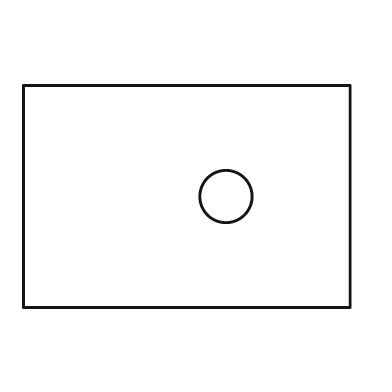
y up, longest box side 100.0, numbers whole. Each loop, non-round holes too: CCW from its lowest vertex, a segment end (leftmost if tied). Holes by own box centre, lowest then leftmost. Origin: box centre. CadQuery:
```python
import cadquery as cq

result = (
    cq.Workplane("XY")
    .moveTo(-50.0, -34.0)
    .lineTo(50.0, -34.0)
    .lineTo(50.0, 34.0)
    .lineTo(-50.0, 34.0)
    .close()
    .moveTo(12.0, 0.0)
    .circle(8.0)
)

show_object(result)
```